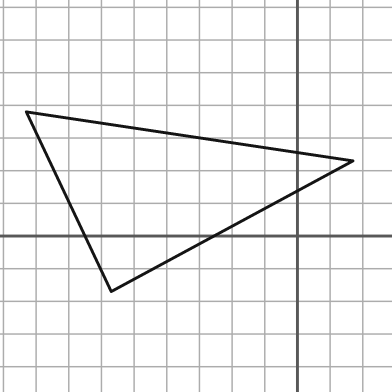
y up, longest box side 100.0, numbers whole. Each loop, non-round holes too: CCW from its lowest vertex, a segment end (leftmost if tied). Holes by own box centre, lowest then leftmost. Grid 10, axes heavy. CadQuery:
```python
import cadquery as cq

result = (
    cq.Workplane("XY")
    .moveTo(-57.0, -17.0)
    .lineTo(17.0, 23.0)
    .lineTo(-83.0, 38.0)
    .close()
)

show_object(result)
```